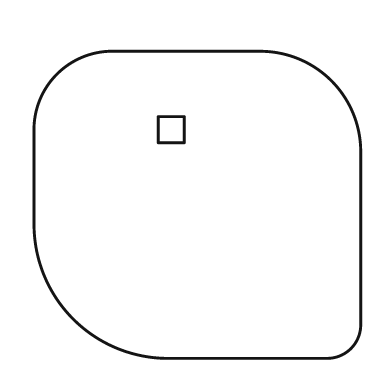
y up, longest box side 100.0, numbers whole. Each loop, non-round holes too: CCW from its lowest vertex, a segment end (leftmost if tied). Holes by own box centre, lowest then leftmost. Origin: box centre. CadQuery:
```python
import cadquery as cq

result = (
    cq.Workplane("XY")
    .moveTo(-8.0, -47.0)
    .lineTo(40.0, -47.0)
    .threePointArc((47.0, -44.0), (50.0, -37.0))
    .lineTo(50.0, 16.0)
    .threePointArc((41.0, 38.0), (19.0, 47.0))
    .lineTo(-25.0, 47.0)
    .threePointArc((-43.0, 40.0), (-50.0, 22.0))
    .lineTo(-50.0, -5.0)
    .threePointArc((-38.0, -35.0), (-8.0, -47.0))
    .close()
    .moveTo(-12.0, 19.0)
    .lineTo(-4.0, 19.0)
    .lineTo(-4.0, 27.0)
    .lineTo(-12.0, 27.0)
    .close()
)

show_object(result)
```